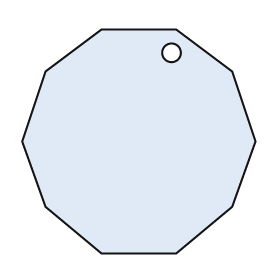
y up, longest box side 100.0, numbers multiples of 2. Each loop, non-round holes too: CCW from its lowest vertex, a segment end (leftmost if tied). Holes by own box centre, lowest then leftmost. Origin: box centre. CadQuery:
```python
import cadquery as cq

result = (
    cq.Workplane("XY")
    .moveTo(-16.0, -48.0)
    .lineTo(16.0, -48.0)
    .lineTo(40.0, -28.0)
    .lineTo(50.0, 0.0)
    .lineTo(40.0, 30.0)
    .lineTo(16.0, 48.0)
    .lineTo(-16.0, 48.0)
    .lineTo(-40.0, 30.0)
    .lineTo(-50.0, 0.0)
    .lineTo(-40.0, -28.0)
    .close()
    .moveTo(14.0, 38.0)
    .circle(4.0)
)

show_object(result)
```